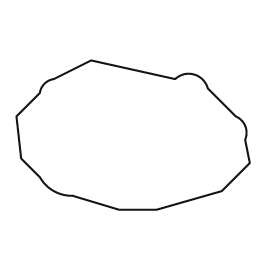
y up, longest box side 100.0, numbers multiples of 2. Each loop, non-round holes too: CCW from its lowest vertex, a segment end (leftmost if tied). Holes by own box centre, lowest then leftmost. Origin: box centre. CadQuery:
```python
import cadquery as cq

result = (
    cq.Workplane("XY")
    .moveTo(-6.0, -32.0)
    .lineTo(10.0, -32.0)
    .lineTo(38.0, -24.0)
    .lineTo(50.0, -12.0)
    .lineTo(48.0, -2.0)
    .threePointArc((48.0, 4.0), (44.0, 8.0))
    .lineTo(32.0, 20.0)
    .threePointArc((26.0, 26.0), (18.0, 24.0))
    .lineTo(-18.0, 32.0)
    .lineTo(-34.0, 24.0)
    .threePointArc((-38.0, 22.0), (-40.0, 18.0))
    .lineTo(-50.0, 8.0)
    .lineTo(-48.0, -10.0)
    .lineTo(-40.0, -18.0)
    .threePointArc((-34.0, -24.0), (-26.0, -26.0))
    .close()
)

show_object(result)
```